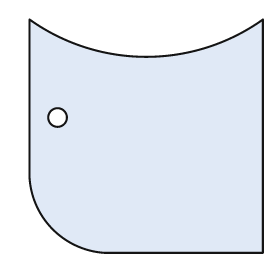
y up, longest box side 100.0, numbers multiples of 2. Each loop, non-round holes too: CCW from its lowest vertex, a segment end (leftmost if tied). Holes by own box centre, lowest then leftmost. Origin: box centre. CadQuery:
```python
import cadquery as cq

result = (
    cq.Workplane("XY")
    .moveTo(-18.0, -50.0)
    .lineTo(50.0, -50.0)
    .lineTo(50.0, 50.0)
    .threePointArc((0.0, 34.0), (-50.0, 50.0))
    .lineTo(-50.0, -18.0)
    .threePointArc((-40.0, -40.0), (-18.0, -50.0))
    .close()
    .moveTo(-38.0, 8.0)
    .circle(4.0)
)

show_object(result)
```